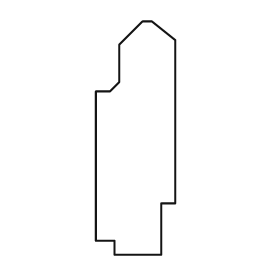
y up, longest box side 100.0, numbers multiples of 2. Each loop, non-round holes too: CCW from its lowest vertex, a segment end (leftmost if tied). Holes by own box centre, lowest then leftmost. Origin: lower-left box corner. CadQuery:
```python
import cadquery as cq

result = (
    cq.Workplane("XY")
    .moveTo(8.0, 0.0)
    .lineTo(28.0, 0.0)
    .lineTo(28.0, 22.0)
    .lineTo(34.0, 22.0)
    .lineTo(34.0, 92.0)
    .lineTo(24.0, 100.0)
    .lineTo(20.0, 100.0)
    .lineTo(10.0, 90.0)
    .lineTo(10.0, 74.0)
    .lineTo(6.0, 70.0)
    .lineTo(0.0, 70.0)
    .lineTo(0.0, 6.0)
    .lineTo(8.0, 6.0)
    .close()
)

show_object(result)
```